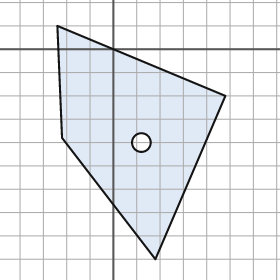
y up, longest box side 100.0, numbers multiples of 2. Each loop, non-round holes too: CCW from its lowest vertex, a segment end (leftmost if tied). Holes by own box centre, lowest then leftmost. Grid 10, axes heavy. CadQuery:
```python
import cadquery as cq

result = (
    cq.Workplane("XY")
    .moveTo(18.0, -90.0)
    .lineTo(48.0, -20.0)
    .lineTo(-24.0, 10.0)
    .lineTo(-22.0, -38.0)
    .close()
    .moveTo(12.0, -40.0)
    .circle(4.0)
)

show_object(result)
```